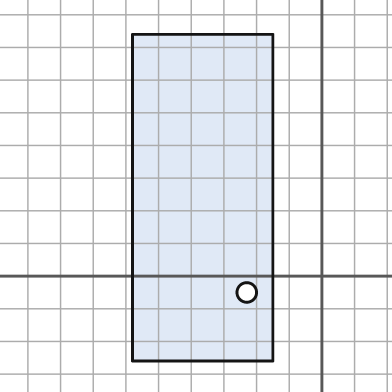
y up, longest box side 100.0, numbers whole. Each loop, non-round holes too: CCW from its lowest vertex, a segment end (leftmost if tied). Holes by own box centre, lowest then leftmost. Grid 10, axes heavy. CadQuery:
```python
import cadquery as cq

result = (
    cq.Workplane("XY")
    .moveTo(-58.0, -26.0)
    .lineTo(-15.0, -26.0)
    .lineTo(-15.0, 74.0)
    .lineTo(-58.0, 74.0)
    .close()
    .moveTo(-23.0, -5.0)
    .circle(3.0)
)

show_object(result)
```